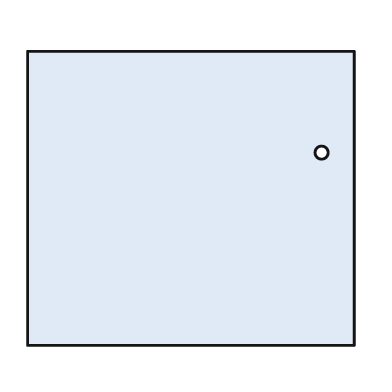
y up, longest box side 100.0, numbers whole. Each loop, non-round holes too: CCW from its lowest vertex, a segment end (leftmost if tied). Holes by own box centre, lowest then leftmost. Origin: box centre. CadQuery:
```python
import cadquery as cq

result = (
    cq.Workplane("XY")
    .moveTo(-50.0, -45.0)
    .lineTo(50.0, -45.0)
    .lineTo(50.0, 45.0)
    .lineTo(-50.0, 45.0)
    .close()
    .moveTo(40.0, 14.0)
    .circle(2.0)
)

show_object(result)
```